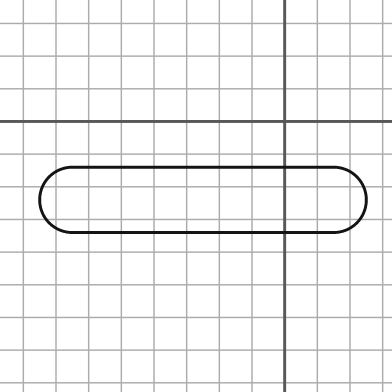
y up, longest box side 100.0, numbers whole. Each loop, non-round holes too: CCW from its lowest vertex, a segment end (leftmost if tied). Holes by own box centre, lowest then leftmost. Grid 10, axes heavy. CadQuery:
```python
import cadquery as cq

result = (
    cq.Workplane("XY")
    .moveTo(-65.0, -34.0)
    .lineTo(15.0, -34.0)
    .threePointArc((25.0, -24.0), (15.0, -14.0))
    .lineTo(-65.0, -14.0)
    .threePointArc((-75.0, -24.0), (-65.0, -34.0))
    .close()
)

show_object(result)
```